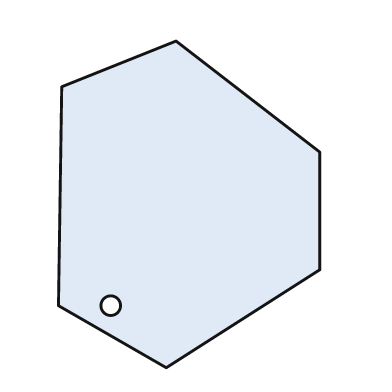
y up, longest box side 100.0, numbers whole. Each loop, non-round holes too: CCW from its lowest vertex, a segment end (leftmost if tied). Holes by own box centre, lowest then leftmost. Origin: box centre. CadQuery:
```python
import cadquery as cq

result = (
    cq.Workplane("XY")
    .moveTo(-7.0, -50.0)
    .lineTo(40.0, -20.0)
    .lineTo(40.0, 16.0)
    .lineTo(-4.0, 50.0)
    .lineTo(-39.0, 36.0)
    .lineTo(-40.0, -31.0)
    .close()
    .moveTo(-24.0, -31.0)
    .circle(3.0)
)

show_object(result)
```